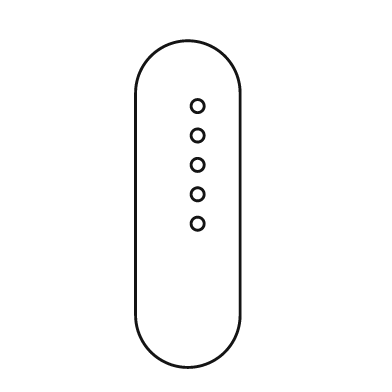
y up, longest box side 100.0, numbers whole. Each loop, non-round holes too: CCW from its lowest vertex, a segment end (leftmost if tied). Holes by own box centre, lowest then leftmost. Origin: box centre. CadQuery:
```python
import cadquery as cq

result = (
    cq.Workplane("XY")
    .moveTo(-16.0, -34.0)
    .threePointArc((0.0, -50.0), (16.0, -34.0))
    .lineTo(16.0, 34.0)
    .threePointArc((0.0, 50.0), (-16.0, 34.0))
    .close()
    .moveTo(3.0, -6.0)
    .circle(2.0)
    .moveTo(3.0, 3.0)
    .circle(2.0)
    .moveTo(3.0, 12.0)
    .circle(2.0)
    .moveTo(3.0, 21.0)
    .circle(2.0)
    .moveTo(3.0, 30.0)
    .circle(2.0)
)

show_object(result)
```